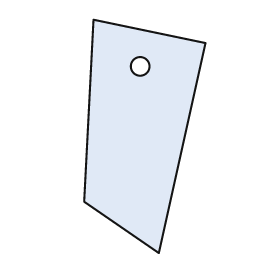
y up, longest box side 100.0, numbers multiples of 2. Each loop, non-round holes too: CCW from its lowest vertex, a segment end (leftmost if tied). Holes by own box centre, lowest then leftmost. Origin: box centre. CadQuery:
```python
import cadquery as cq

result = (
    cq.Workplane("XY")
    .moveTo(6.0, -50.0)
    .lineTo(26.0, 40.0)
    .lineTo(-22.0, 50.0)
    .lineTo(-26.0, -28.0)
    .close()
    .moveTo(-2.0, 30.0)
    .circle(4.0)
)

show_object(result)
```